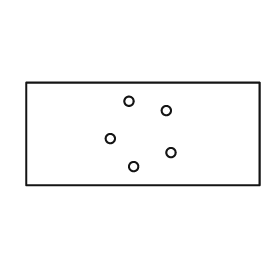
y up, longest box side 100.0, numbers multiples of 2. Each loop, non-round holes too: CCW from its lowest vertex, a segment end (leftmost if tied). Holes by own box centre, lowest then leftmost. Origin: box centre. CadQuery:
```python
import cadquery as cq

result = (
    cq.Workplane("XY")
    .moveTo(-50.0, -22.0)
    .lineTo(50.0, -22.0)
    .lineTo(50.0, 22.0)
    .lineTo(-50.0, 22.0)
    .close()
    .moveTo(-4.0, -14.0)
    .circle(2.0)
    .moveTo(12.0, -8.0)
    .circle(2.0)
    .moveTo(-14.0, -2.0)
    .circle(2.0)
    .moveTo(10.0, 10.0)
    .circle(2.0)
    .moveTo(-6.0, 14.0)
    .circle(2.0)
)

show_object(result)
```